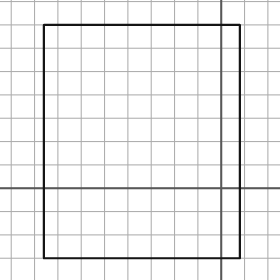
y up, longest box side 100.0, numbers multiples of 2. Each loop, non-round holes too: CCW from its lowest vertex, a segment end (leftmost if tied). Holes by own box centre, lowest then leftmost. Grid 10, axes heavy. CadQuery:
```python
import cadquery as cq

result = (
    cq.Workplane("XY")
    .moveTo(-76.0, -30.0)
    .lineTo(8.0, -30.0)
    .lineTo(8.0, 70.0)
    .lineTo(-76.0, 70.0)
    .close()
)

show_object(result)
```